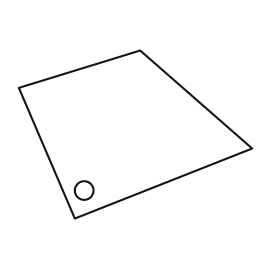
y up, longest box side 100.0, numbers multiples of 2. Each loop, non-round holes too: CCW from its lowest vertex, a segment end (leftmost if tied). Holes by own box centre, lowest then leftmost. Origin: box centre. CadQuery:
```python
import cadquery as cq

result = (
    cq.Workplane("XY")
    .moveTo(-26.0, -36.0)
    .lineTo(50.0, -6.0)
    .lineTo(2.0, 36.0)
    .lineTo(-50.0, 20.0)
    .close()
    .moveTo(-22.0, -24.0)
    .circle(4.0)
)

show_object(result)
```